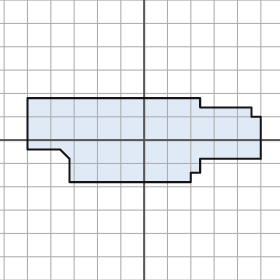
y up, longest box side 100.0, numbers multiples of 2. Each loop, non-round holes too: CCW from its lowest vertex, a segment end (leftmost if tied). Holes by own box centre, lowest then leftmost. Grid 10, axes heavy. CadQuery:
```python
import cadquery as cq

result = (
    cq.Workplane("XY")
    .moveTo(-32.0, -18.0)
    .lineTo(20.0, -18.0)
    .lineTo(20.0, -14.0)
    .lineTo(24.0, -14.0)
    .lineTo(24.0, -8.0)
    .lineTo(50.0, -8.0)
    .lineTo(50.0, 10.0)
    .lineTo(46.0, 10.0)
    .lineTo(46.0, 14.0)
    .lineTo(24.0, 14.0)
    .lineTo(24.0, 18.0)
    .lineTo(-50.0, 18.0)
    .lineTo(-50.0, -4.0)
    .lineTo(-36.0, -4.0)
    .lineTo(-32.0, -8.0)
    .close()
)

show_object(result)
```